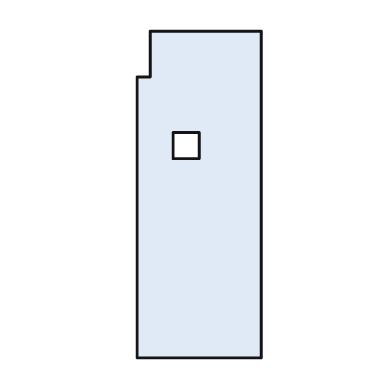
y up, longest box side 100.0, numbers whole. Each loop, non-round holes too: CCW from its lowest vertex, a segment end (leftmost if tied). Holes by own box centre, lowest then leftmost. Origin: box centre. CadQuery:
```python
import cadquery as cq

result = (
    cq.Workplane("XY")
    .moveTo(-19.0, -50.0)
    .lineTo(19.0, -50.0)
    .lineTo(19.0, 50.0)
    .lineTo(-15.0, 50.0)
    .lineTo(-15.0, 36.0)
    .lineTo(-19.0, 36.0)
    .close()
    .moveTo(-8.0, 11.0)
    .lineTo(0.0, 11.0)
    .lineTo(0.0, 19.0)
    .lineTo(-8.0, 19.0)
    .close()
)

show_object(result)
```